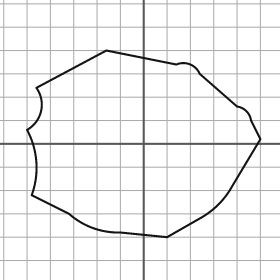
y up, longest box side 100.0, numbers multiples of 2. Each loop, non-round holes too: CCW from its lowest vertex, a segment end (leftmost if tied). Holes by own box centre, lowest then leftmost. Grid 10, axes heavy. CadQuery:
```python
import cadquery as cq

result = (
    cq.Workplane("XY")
    .moveTo(10.0, -40.0)
    .lineTo(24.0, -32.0)
    .threePointArc((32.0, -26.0), (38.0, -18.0))
    .lineTo(50.0, 2.0)
    .lineTo(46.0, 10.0)
    .threePointArc((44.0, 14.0), (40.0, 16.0))
    .lineTo(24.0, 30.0)
    .threePointArc((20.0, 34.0), (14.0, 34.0))
    .lineTo(-16.0, 40.0)
    .lineTo(-46.0, 24.0)
    .threePointArc((-44.0, 14.0), (-50.0, 6.0))
    .threePointArc((-46.0, -8.0), (-48.0, -22.0))
    .lineTo(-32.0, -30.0)
    .threePointArc((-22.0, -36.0), (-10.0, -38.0))
    .close()
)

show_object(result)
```